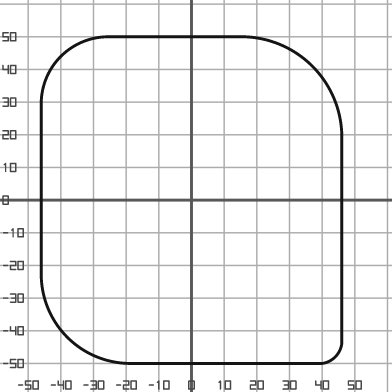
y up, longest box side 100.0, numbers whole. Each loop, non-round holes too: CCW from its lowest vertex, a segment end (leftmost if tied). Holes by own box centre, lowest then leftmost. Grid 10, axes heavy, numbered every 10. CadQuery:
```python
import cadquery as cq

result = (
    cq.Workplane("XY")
    .moveTo(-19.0, -50.0)
    .lineTo(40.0, -50.0)
    .threePointArc((44.0, -48.0), (46.0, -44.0))
    .lineTo(46.0, 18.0)
    .threePointArc((37.0, 41.0), (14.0, 50.0))
    .lineTo(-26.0, 50.0)
    .threePointArc((-40.0, 44.0), (-46.0, 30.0))
    .lineTo(-46.0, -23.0)
    .threePointArc((-38.0, -42.0), (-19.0, -50.0))
    .close()
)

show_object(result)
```